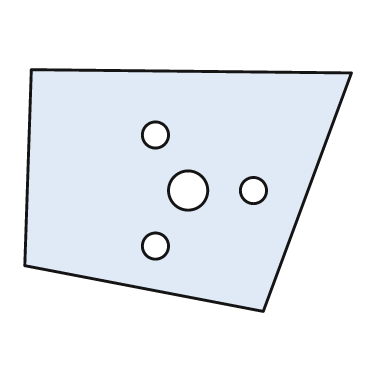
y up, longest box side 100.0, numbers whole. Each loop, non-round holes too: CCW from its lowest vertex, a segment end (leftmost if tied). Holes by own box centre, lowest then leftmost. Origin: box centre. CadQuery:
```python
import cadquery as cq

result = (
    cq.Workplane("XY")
    .moveTo(23.0, -37.0)
    .lineTo(50.0, 36.0)
    .lineTo(-48.0, 37.0)
    .lineTo(-50.0, -23.0)
    .close()
    .moveTo(-10.0, -17.0)
    .circle(4.0)
    .moveTo(0.0, 0.0)
    .circle(6.0)
    .moveTo(20.0, 0.0)
    .circle(4.0)
    .moveTo(-10.0, 17.0)
    .circle(4.0)
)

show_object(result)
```